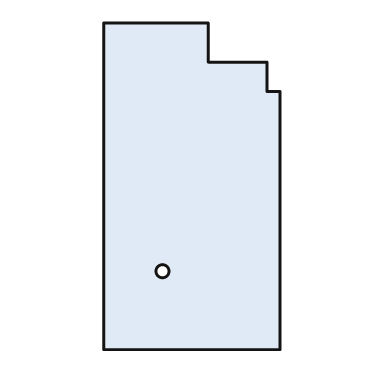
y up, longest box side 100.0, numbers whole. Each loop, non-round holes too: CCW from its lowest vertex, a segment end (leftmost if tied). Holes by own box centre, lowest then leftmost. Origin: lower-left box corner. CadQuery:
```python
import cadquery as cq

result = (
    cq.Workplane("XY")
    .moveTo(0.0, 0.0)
    .lineTo(54.0, 0.0)
    .lineTo(54.0, 79.0)
    .lineTo(50.0, 79.0)
    .lineTo(50.0, 88.0)
    .lineTo(32.0, 88.0)
    .lineTo(32.0, 100.0)
    .lineTo(0.0, 100.0)
    .close()
    .moveTo(18.0, 24.0)
    .circle(2.0)
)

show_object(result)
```